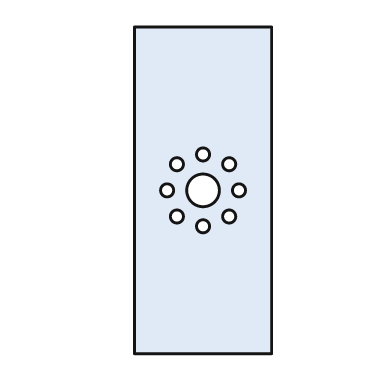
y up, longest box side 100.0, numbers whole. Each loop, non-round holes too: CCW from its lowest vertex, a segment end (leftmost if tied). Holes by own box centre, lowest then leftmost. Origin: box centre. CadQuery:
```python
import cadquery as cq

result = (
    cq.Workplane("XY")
    .moveTo(-21.0, -50.0)
    .lineTo(21.0, -50.0)
    .lineTo(21.0, 50.0)
    .lineTo(-21.0, 50.0)
    .close()
    .moveTo(0.0, -11.0)
    .circle(2.0)
    .moveTo(-8.0, -8.0)
    .circle(2.0)
    .moveTo(8.0, -8.0)
    .circle(2.0)
    .moveTo(-11.0, 0.0)
    .circle(2.0)
    .moveTo(0.0, 0.0)
    .circle(5.0)
    .moveTo(11.0, 0.0)
    .circle(2.0)
    .moveTo(-8.0, 8.0)
    .circle(2.0)
    .moveTo(8.0, 8.0)
    .circle(2.0)
    .moveTo(0.0, 11.0)
    .circle(2.0)
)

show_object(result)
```